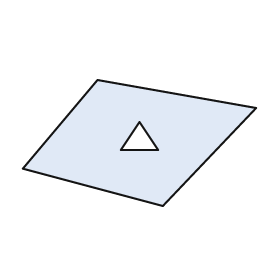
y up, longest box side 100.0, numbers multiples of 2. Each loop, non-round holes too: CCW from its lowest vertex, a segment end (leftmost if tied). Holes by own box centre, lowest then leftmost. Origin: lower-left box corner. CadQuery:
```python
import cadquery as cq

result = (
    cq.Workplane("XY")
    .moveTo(60.0, 0.0)
    .lineTo(100.0, 42.0)
    .lineTo(32.0, 54.0)
    .lineTo(0.0, 16.0)
    .close()
    .moveTo(42.0, 24.0)
    .lineTo(58.0, 24.0)
    .lineTo(50.0, 36.0)
    .close()
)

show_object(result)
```